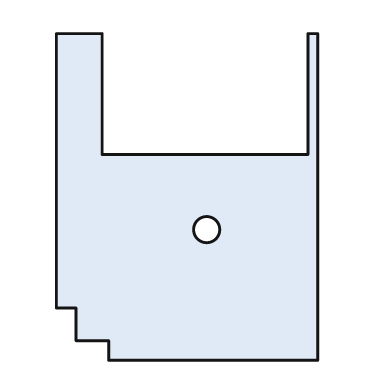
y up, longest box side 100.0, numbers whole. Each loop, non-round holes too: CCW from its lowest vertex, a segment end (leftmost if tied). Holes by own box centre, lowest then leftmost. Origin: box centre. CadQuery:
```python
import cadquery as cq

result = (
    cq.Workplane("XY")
    .moveTo(-24.0, -50.0)
    .lineTo(40.0, -50.0)
    .lineTo(40.0, 50.0)
    .lineTo(37.0, 50.0)
    .lineTo(37.0, 13.0)
    .lineTo(-26.0, 13.0)
    .lineTo(-26.0, 50.0)
    .lineTo(-40.0, 50.0)
    .lineTo(-40.0, -34.0)
    .lineTo(-34.0, -34.0)
    .lineTo(-34.0, -44.0)
    .lineTo(-24.0, -44.0)
    .close()
    .moveTo(6.0, -10.0)
    .circle(4.0)
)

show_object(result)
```